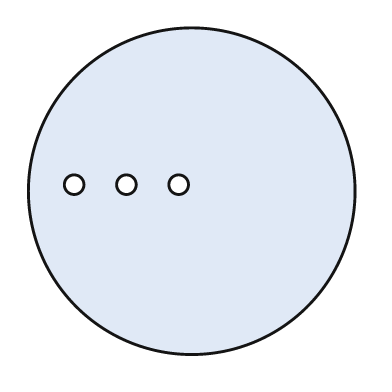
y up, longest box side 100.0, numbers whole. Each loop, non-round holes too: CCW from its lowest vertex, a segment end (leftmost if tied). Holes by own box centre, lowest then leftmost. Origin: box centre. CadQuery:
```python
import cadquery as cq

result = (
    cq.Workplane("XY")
    .moveTo(0.0, 0.0)
    .circle(50.0)
    .moveTo(-36.0, 2.0)
    .circle(3.0)
    .moveTo(-20.0, 2.0)
    .circle(3.0)
    .moveTo(-4.0, 2.0)
    .circle(3.0)
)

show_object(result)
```